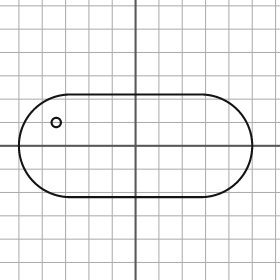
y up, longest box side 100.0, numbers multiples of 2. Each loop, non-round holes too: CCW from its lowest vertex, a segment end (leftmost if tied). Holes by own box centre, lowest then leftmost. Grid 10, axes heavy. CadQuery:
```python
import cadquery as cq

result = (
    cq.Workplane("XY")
    .moveTo(-28.0, -22.0)
    .lineTo(28.0, -22.0)
    .threePointArc((50.0, 0.0), (28.0, 22.0))
    .lineTo(-28.0, 22.0)
    .threePointArc((-50.0, 0.0), (-28.0, -22.0))
    .close()
    .moveTo(-34.0, 10.0)
    .circle(2.0)
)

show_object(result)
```